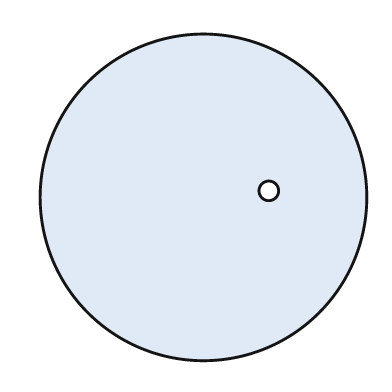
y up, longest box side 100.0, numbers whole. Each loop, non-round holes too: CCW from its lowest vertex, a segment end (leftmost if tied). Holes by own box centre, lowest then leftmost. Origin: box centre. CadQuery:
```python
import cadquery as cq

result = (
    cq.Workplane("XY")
    .moveTo(0.0, 0.0)
    .circle(50.0)
    .moveTo(20.0, 2.0)
    .circle(3.0)
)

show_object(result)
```